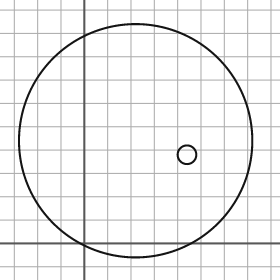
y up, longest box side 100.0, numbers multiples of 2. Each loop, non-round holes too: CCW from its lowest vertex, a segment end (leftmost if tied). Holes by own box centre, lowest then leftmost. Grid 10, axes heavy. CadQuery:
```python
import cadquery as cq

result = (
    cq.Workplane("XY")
    .moveTo(22.0, 44.0)
    .circle(50.0)
    .moveTo(44.0, 38.0)
    .circle(4.0)
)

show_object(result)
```